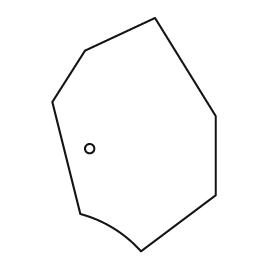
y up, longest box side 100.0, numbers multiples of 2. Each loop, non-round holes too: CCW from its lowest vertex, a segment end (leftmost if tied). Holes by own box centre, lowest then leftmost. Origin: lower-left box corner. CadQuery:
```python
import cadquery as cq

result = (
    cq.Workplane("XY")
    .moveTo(38.0, 0.0)
    .lineTo(70.0, 24.0)
    .lineTo(70.0, 58.0)
    .lineTo(44.0, 100.0)
    .lineTo(14.0, 86.0)
    .lineTo(0.0, 64.0)
    .lineTo(12.0, 16.0)
    .threePointArc((26.0, 10.0), (38.0, 0.0))
    .close()
    .moveTo(16.0, 44.0)
    .circle(2.0)
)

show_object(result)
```